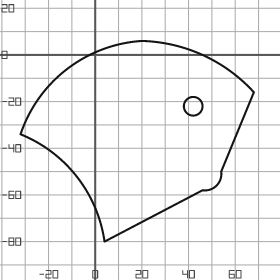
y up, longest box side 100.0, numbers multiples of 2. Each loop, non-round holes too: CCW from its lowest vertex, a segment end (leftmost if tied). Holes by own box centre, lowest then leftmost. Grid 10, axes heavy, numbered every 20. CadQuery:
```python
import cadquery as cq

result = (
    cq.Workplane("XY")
    .moveTo(4.0, -80.0)
    .lineTo(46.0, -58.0)
    .threePointArc((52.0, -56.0), (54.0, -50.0))
    .lineTo(68.0, -16.0)
    .threePointArc((46.0, 0.0), (20.0, 6.0))
    .threePointArc((-12.0, -6.0), (-32.0, -34.0))
    .threePointArc((-8.0, -52.0), (4.0, -80.0))
    .close()
    .moveTo(42.0, -22.0)
    .circle(4.0)
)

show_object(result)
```